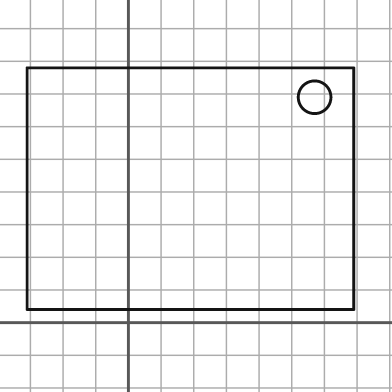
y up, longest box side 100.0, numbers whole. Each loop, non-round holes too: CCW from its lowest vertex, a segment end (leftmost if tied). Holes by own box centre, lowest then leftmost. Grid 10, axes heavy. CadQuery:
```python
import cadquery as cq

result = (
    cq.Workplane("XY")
    .moveTo(-31.0, 4.0)
    .lineTo(69.0, 4.0)
    .lineTo(69.0, 78.0)
    .lineTo(-31.0, 78.0)
    .close()
    .moveTo(57.0, 69.0)
    .circle(5.0)
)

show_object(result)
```